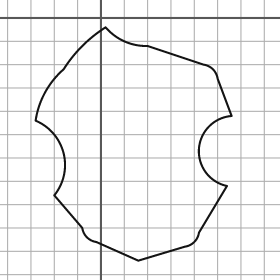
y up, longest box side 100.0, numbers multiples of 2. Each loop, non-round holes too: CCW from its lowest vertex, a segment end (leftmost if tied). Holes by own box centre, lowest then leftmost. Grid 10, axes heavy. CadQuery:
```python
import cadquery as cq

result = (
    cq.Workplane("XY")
    .moveTo(16.0, -104.0)
    .lineTo(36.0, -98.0)
    .threePointArc((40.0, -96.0), (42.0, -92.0))
    .lineTo(54.0, -72.0)
    .threePointArc((42.0, -56.0), (56.0, -42.0))
    .lineTo(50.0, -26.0)
    .threePointArc((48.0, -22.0), (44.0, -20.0))
    .lineTo(20.0, -12.0)
    .threePointArc((10.0, -10.0), (2.0, -4.0))
    .threePointArc((-8.0, -12.0), (-16.0, -22.0))
    .threePointArc((-24.0, -32.0), (-28.0, -44.0))
    .threePointArc((-16.0, -58.0), (-20.0, -76.0))
    .lineTo(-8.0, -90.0)
    .threePointArc((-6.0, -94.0), (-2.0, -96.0))
    .close()
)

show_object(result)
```